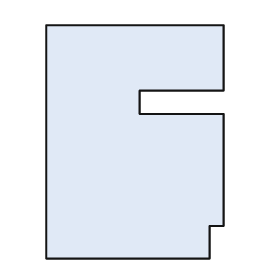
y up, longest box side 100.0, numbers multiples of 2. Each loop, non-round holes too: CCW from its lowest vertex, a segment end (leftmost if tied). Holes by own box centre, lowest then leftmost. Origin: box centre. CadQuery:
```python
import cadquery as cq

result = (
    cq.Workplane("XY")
    .moveTo(-38.0, -50.0)
    .lineTo(32.0, -50.0)
    .lineTo(32.0, -36.0)
    .lineTo(38.0, -36.0)
    .lineTo(38.0, 12.0)
    .lineTo(2.0, 12.0)
    .lineTo(2.0, 22.0)
    .lineTo(38.0, 22.0)
    .lineTo(38.0, 50.0)
    .lineTo(-38.0, 50.0)
    .close()
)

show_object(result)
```